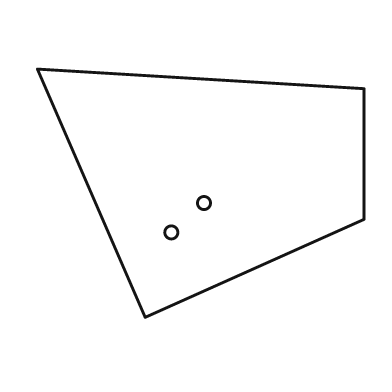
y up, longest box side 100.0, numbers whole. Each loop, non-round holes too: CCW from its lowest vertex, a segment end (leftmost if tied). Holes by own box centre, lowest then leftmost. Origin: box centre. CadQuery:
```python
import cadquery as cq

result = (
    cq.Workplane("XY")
    .moveTo(-17.0, -38.0)
    .lineTo(50.0, -8.0)
    .lineTo(50.0, 32.0)
    .lineTo(-50.0, 38.0)
    .close()
    .moveTo(-9.0, -12.0)
    .circle(2.0)
    .moveTo(1.0, -3.0)
    .circle(2.0)
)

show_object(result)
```